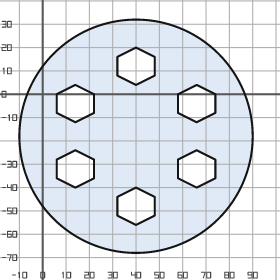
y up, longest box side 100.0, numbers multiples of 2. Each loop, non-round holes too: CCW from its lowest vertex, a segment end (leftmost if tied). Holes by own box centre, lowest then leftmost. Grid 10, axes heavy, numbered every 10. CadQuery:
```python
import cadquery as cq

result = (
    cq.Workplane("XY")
    .moveTo(40.0, -18.0)
    .circle(50.0)
    .moveTo(40.0, -56.0)
    .lineTo(48.0, -52.0)
    .lineTo(48.0, -44.0)
    .lineTo(40.0, -40.0)
    .lineTo(32.0, -44.0)
    .lineTo(32.0, -52.0)
    .close()
    .moveTo(14.0, -40.0)
    .lineTo(22.0, -36.0)
    .lineTo(22.0, -28.0)
    .lineTo(14.0, -24.0)
    .lineTo(6.0, -28.0)
    .lineTo(6.0, -36.0)
    .close()
    .moveTo(66.0, -40.0)
    .lineTo(74.0, -36.0)
    .lineTo(74.0, -28.0)
    .lineTo(66.0, -24.0)
    .lineTo(58.0, -28.0)
    .lineTo(58.0, -36.0)
    .close()
    .moveTo(14.0, -12.0)
    .lineTo(22.0, -8.0)
    .lineTo(22.0, 0.0)
    .lineTo(14.0, 4.0)
    .lineTo(6.0, 0.0)
    .lineTo(6.0, -8.0)
    .close()
    .moveTo(66.0, -12.0)
    .lineTo(74.0, -8.0)
    .lineTo(74.0, 0.0)
    .lineTo(66.0, 4.0)
    .lineTo(58.0, 0.0)
    .lineTo(58.0, -8.0)
    .close()
    .moveTo(40.0, 4.0)
    .lineTo(48.0, 8.0)
    .lineTo(48.0, 16.0)
    .lineTo(40.0, 20.0)
    .lineTo(32.0, 16.0)
    .lineTo(32.0, 8.0)
    .close()
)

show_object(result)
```